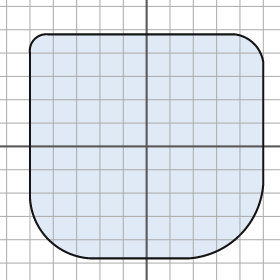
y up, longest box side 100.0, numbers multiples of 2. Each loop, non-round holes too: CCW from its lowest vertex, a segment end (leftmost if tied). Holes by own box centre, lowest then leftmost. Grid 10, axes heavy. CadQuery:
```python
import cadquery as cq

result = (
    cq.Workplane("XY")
    .moveTo(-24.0, -48.0)
    .lineTo(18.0, -48.0)
    .threePointArc((40.0, -38.0), (50.0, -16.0))
    .lineTo(50.0, 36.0)
    .threePointArc((46.0, 44.0), (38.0, 48.0))
    .lineTo(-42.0, 48.0)
    .threePointArc((-48.0, 46.0), (-50.0, 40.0))
    .lineTo(-50.0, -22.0)
    .threePointArc((-42.0, -40.0), (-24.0, -48.0))
    .close()
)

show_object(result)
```